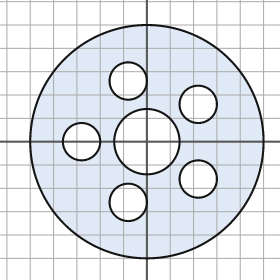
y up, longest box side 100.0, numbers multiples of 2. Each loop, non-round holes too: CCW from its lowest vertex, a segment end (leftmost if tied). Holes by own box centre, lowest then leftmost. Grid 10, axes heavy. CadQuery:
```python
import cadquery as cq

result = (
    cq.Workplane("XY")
    .moveTo(0.0, 0.0)
    .circle(50.0)
    .moveTo(-8.0, -26.0)
    .circle(8.0)
    .moveTo(22.0, -16.0)
    .circle(8.0)
    .moveTo(-28.0, 0.0)
    .circle(8.0)
    .moveTo(0.0, 0.0)
    .circle(14.0)
    .moveTo(22.0, 16.0)
    .circle(8.0)
    .moveTo(-8.0, 26.0)
    .circle(8.0)
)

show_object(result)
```